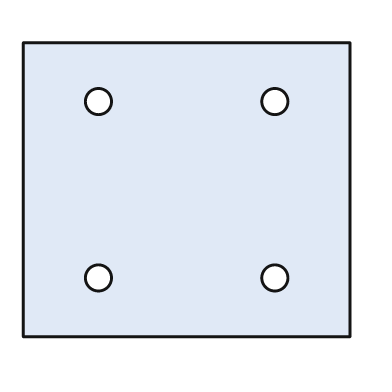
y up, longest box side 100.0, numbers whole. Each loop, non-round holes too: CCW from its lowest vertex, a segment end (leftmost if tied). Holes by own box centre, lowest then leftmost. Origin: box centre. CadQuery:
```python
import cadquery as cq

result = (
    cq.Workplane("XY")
    .moveTo(-50.0, -45.0)
    .lineTo(50.0, -45.0)
    .lineTo(50.0, 45.0)
    .lineTo(-50.0, 45.0)
    .close()
    .moveTo(-27.0, -27.0)
    .circle(4.0)
    .moveTo(27.0, -27.0)
    .circle(4.0)
    .moveTo(-27.0, 27.0)
    .circle(4.0)
    .moveTo(27.0, 27.0)
    .circle(4.0)
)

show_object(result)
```